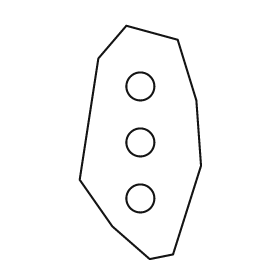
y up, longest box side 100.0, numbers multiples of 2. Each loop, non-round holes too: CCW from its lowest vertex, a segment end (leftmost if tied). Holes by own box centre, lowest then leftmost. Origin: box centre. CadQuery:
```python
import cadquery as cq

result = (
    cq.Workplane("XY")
    .moveTo(4.0, -50.0)
    .lineTo(14.0, -48.0)
    .lineTo(26.0, -10.0)
    .lineTo(24.0, 18.0)
    .lineTo(16.0, 44.0)
    .lineTo(-6.0, 50.0)
    .lineTo(-18.0, 36.0)
    .lineTo(-26.0, -16.0)
    .lineTo(-12.0, -36.0)
    .close()
    .moveTo(0.0, -24.0)
    .circle(6.0)
    .moveTo(0.0, 0.0)
    .circle(6.0)
    .moveTo(0.0, 24.0)
    .circle(6.0)
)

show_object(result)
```